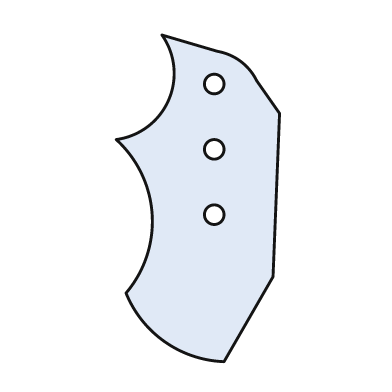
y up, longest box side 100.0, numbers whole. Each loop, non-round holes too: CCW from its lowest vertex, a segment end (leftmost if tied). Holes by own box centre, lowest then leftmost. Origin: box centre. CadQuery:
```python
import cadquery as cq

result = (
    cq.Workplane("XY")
    .moveTo(8.0, -50.0)
    .lineTo(23.0, -24.0)
    .lineTo(25.0, 26.0)
    .lineTo(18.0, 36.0)
    .threePointArc((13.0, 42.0), (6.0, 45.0))
    .lineTo(-11.0, 50.0)
    .threePointArc((-9.0, 30.0), (-25.0, 18.0))
    .threePointArc((-14.0, -5.0), (-22.0, -29.0))
    .threePointArc((-10.0, -44.0), (8.0, -50.0))
    .close()
    .moveTo(5.0, -5.0)
    .circle(3.0)
    .moveTo(5.0, 15.0)
    .circle(3.0)
    .moveTo(5.0, 35.0)
    .circle(3.0)
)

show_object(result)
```